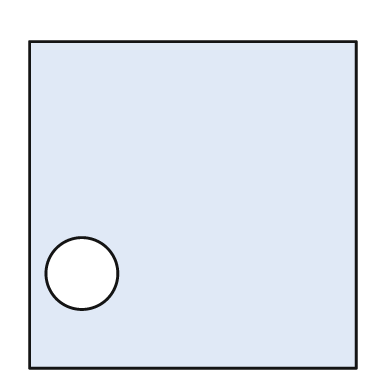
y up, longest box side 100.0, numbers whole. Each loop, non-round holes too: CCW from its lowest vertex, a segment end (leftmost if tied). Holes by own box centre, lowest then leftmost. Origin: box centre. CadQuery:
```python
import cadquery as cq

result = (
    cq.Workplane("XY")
    .moveTo(-50.0, -50.0)
    .lineTo(50.0, -50.0)
    .lineTo(50.0, 50.0)
    .lineTo(-50.0, 50.0)
    .close()
    .moveTo(-34.0, -21.0)
    .circle(11.0)
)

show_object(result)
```